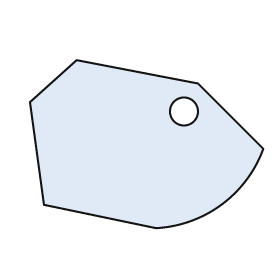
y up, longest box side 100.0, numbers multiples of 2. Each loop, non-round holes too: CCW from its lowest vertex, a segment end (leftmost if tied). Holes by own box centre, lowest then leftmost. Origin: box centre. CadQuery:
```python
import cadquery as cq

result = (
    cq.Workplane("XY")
    .moveTo(4.0, -36.0)
    .threePointArc((32.0, -26.0), (50.0, -2.0))
    .lineTo(22.0, 26.0)
    .lineTo(-30.0, 36.0)
    .lineTo(-50.0, 18.0)
    .lineTo(-44.0, -26.0)
    .close()
    .moveTo(16.0, 14.0)
    .circle(6.0)
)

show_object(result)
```